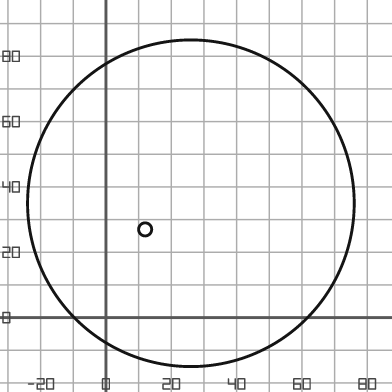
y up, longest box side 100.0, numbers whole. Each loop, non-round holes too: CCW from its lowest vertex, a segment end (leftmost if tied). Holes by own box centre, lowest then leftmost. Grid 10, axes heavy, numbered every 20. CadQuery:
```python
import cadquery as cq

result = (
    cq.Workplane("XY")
    .moveTo(26.0, 35.0)
    .circle(50.0)
    .moveTo(12.0, 27.0)
    .circle(2.0)
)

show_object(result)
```